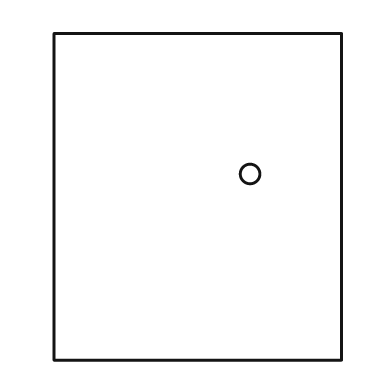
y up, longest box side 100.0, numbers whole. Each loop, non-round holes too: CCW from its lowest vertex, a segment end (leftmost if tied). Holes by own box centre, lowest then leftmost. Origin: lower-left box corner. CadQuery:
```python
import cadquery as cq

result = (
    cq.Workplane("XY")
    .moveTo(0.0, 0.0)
    .lineTo(88.0, 0.0)
    .lineTo(88.0, 100.0)
    .lineTo(0.0, 100.0)
    .close()
    .moveTo(60.0, 57.0)
    .circle(3.0)
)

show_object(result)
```